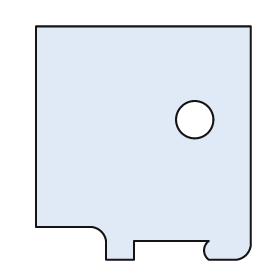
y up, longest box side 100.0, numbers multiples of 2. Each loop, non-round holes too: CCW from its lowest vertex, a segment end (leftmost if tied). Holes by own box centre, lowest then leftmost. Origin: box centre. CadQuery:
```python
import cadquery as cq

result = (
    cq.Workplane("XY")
    .moveTo(-16.0, -50.0)
    .lineTo(-4.0, -50.0)
    .lineTo(-4.0, -42.0)
    .lineTo(28.0, -42.0)
    .threePointArc((26.0, -46.0), (28.0, -50.0))
    .lineTo(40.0, -50.0)
    .threePointArc((44.0, -48.0), (46.0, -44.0))
    .lineTo(46.0, 50.0)
    .lineTo(-46.0, 50.0)
    .lineTo(-46.0, -36.0)
    .lineTo(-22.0, -36.0)
    .threePointArc((-18.0, -38.0), (-16.0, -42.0))
    .close()
    .moveTo(22.0, 10.0)
    .circle(8.0)
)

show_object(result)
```